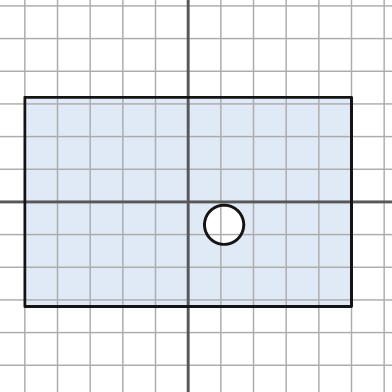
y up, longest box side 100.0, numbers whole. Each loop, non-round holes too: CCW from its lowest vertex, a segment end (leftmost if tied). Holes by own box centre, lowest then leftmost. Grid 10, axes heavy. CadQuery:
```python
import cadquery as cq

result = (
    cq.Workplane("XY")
    .moveTo(-50.0, -32.0)
    .lineTo(50.0, -32.0)
    .lineTo(50.0, 32.0)
    .lineTo(-50.0, 32.0)
    .close()
    .moveTo(11.0, -7.0)
    .circle(6.0)
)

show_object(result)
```